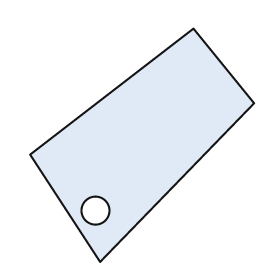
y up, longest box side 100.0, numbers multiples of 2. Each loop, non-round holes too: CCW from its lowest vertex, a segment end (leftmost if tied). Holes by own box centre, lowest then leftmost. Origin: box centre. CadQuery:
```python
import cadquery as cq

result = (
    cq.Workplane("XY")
    .moveTo(-18.0, -50.0)
    .lineTo(48.0, 18.0)
    .lineTo(22.0, 50.0)
    .lineTo(-48.0, -4.0)
    .close()
    .moveTo(-20.0, -28.0)
    .circle(6.0)
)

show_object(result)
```